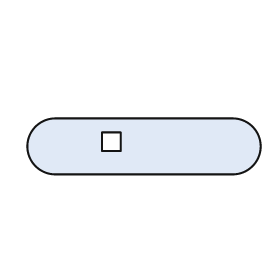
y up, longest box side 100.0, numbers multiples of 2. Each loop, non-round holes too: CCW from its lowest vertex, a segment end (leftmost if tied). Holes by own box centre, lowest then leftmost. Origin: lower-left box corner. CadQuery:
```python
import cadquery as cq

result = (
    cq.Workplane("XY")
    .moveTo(12.0, 0.0)
    .lineTo(88.0, 0.0)
    .threePointArc((100.0, 12.0), (88.0, 24.0))
    .lineTo(12.0, 24.0)
    .threePointArc((0.0, 12.0), (12.0, 0.0))
    .close()
    .moveTo(32.0, 10.0)
    .lineTo(40.0, 10.0)
    .lineTo(40.0, 18.0)
    .lineTo(32.0, 18.0)
    .close()
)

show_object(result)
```